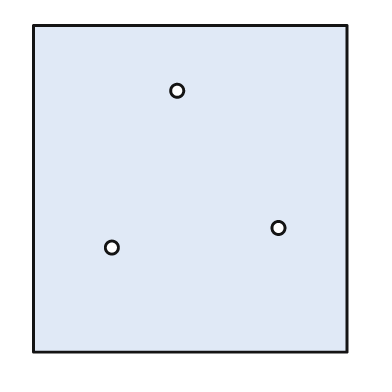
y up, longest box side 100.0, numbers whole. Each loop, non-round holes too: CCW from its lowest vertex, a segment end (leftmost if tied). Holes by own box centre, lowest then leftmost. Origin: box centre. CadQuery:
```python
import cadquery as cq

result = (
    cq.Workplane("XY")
    .moveTo(-48.0, -50.0)
    .lineTo(48.0, -50.0)
    .lineTo(48.0, 50.0)
    .lineTo(-48.0, 50.0)
    .close()
    .moveTo(-24.0, -18.0)
    .circle(2.0)
    .moveTo(27.0, -12.0)
    .circle(2.0)
    .moveTo(-4.0, 30.0)
    .circle(2.0)
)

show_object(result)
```